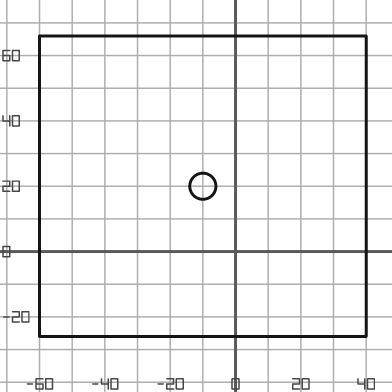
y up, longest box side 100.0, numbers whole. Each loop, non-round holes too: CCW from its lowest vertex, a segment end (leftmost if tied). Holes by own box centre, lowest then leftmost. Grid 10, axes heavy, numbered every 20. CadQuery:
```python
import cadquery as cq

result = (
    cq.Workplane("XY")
    .moveTo(-60.0, -26.0)
    .lineTo(40.0, -26.0)
    .lineTo(40.0, 66.0)
    .lineTo(-60.0, 66.0)
    .close()
    .moveTo(-10.0, 20.0)
    .circle(4.0)
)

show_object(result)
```